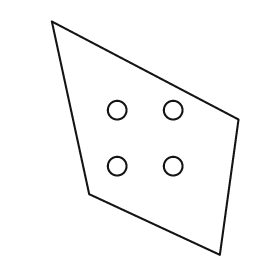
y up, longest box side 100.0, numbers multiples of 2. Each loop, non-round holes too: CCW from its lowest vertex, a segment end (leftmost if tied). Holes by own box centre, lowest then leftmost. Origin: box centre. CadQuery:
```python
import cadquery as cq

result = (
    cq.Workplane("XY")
    .moveTo(32.0, -50.0)
    .lineTo(40.0, 8.0)
    .lineTo(-40.0, 50.0)
    .lineTo(-24.0, -24.0)
    .close()
    .moveTo(-12.0, -12.0)
    .circle(4.0)
    .moveTo(12.0, -12.0)
    .circle(4.0)
    .moveTo(-12.0, 12.0)
    .circle(4.0)
    .moveTo(12.0, 12.0)
    .circle(4.0)
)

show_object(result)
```